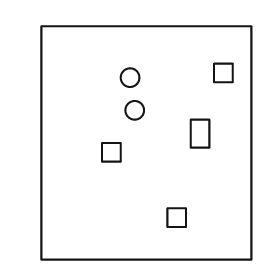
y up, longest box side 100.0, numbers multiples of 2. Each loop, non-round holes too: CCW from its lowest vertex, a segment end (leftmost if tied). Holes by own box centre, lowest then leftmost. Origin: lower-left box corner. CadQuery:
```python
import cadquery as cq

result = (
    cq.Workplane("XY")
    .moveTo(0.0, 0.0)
    .lineTo(90.0, 0.0)
    .lineTo(90.0, 100.0)
    .lineTo(0.0, 100.0)
    .close()
    .moveTo(54.0, 14.0)
    .lineTo(62.0, 14.0)
    .lineTo(62.0, 22.0)
    .lineTo(54.0, 22.0)
    .close()
    .moveTo(26.0, 42.0)
    .lineTo(34.0, 42.0)
    .lineTo(34.0, 50.0)
    .lineTo(26.0, 50.0)
    .close()
    .moveTo(64.0, 48.0)
    .lineTo(72.0, 48.0)
    .lineTo(72.0, 60.0)
    .lineTo(64.0, 60.0)
    .close()
    .moveTo(40.0, 64.0)
    .circle(4.0)
    .moveTo(38.0, 78.0)
    .circle(4.0)
    .moveTo(74.0, 76.0)
    .lineTo(82.0, 76.0)
    .lineTo(82.0, 84.0)
    .lineTo(74.0, 84.0)
    .close()
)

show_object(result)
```